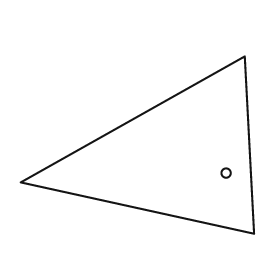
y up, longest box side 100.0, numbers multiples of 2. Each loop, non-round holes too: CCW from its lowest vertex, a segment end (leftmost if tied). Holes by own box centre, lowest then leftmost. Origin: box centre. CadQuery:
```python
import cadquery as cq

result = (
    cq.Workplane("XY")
    .moveTo(50.0, -38.0)
    .lineTo(46.0, 38.0)
    .lineTo(-50.0, -16.0)
    .close()
    .moveTo(38.0, -12.0)
    .circle(2.0)
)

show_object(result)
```